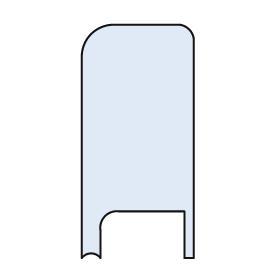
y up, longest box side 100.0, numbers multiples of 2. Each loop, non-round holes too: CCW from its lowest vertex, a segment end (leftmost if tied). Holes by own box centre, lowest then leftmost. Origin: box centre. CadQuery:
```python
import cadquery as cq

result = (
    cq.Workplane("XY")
    .moveTo(-24.0, -50.0)
    .threePointArc((-20.0, -48.0), (-16.0, -50.0))
    .lineTo(-16.0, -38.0)
    .threePointArc((-14.0, -32.0), (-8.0, -30.0))
    .lineTo(20.0, -30.0)
    .lineTo(20.0, -50.0)
    .lineTo(24.0, -50.0)
    .lineTo(24.0, 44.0)
    .threePointArc((22.0, 48.0), (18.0, 50.0))
    .lineTo(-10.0, 50.0)
    .threePointArc((-20.0, 46.0), (-24.0, 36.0))
    .close()
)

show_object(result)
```